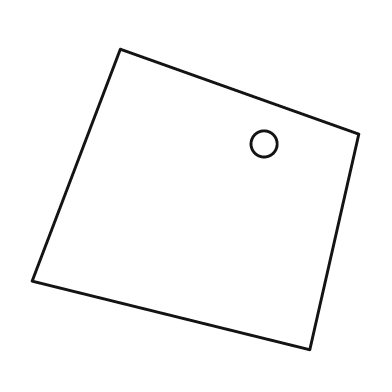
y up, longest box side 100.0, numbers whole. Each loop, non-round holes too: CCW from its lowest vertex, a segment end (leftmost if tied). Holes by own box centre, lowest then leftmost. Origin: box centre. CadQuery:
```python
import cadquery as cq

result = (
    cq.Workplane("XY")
    .moveTo(35.0, -46.0)
    .lineTo(50.0, 20.0)
    .lineTo(-23.0, 46.0)
    .lineTo(-50.0, -25.0)
    .close()
    .moveTo(21.0, 17.0)
    .circle(4.0)
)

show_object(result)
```